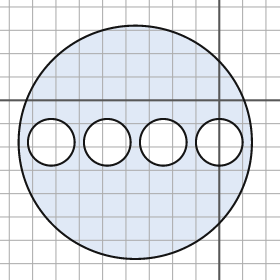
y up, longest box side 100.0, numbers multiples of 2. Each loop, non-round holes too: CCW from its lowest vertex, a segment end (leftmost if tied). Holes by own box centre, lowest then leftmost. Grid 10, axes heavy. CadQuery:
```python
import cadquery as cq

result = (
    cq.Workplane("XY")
    .moveTo(-36.0, -18.0)
    .circle(50.0)
    .moveTo(-72.0, -18.0)
    .circle(10.0)
    .moveTo(-48.0, -18.0)
    .circle(10.0)
    .moveTo(-24.0, -18.0)
    .circle(10.0)
    .moveTo(0.0, -18.0)
    .circle(10.0)
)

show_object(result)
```